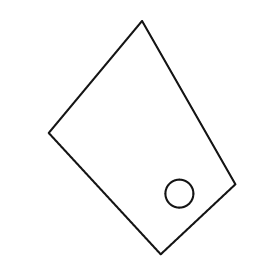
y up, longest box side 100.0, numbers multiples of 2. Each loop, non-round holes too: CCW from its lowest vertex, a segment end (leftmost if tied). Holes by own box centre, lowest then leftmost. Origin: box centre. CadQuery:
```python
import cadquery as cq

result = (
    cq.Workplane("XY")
    .moveTo(8.0, -50.0)
    .lineTo(40.0, -20.0)
    .lineTo(0.0, 50.0)
    .lineTo(-40.0, 2.0)
    .close()
    .moveTo(16.0, -24.0)
    .circle(6.0)
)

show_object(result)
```